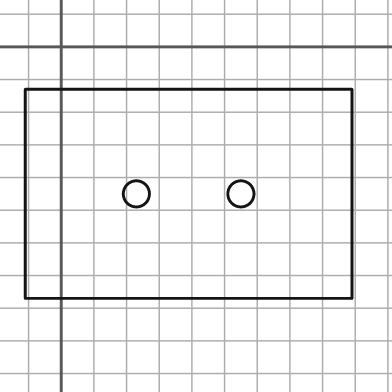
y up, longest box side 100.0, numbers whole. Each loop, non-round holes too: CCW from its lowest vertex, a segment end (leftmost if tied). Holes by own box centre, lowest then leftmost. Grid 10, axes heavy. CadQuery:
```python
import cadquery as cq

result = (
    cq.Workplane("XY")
    .moveTo(-11.0, -77.0)
    .lineTo(89.0, -77.0)
    .lineTo(89.0, -13.0)
    .lineTo(-11.0, -13.0)
    .close()
    .moveTo(23.0, -45.0)
    .circle(4.0)
    .moveTo(55.0, -45.0)
    .circle(4.0)
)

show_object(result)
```